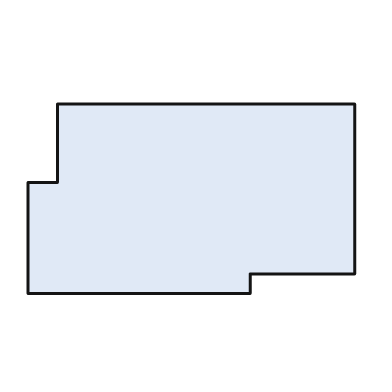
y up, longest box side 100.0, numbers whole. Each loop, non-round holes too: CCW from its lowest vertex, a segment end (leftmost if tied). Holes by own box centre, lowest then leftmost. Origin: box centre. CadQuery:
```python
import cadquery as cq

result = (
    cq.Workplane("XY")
    .moveTo(-50.0, -29.0)
    .lineTo(18.0, -29.0)
    .lineTo(18.0, -23.0)
    .lineTo(50.0, -23.0)
    .lineTo(50.0, 29.0)
    .lineTo(-41.0, 29.0)
    .lineTo(-41.0, 5.0)
    .lineTo(-50.0, 5.0)
    .close()
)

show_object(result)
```